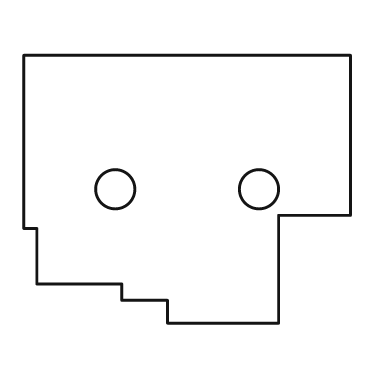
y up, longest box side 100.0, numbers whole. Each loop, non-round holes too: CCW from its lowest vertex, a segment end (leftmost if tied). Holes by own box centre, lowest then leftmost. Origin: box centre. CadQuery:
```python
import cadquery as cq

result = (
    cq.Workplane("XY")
    .moveTo(-6.0, -41.0)
    .lineTo(28.0, -41.0)
    .lineTo(28.0, -8.0)
    .lineTo(50.0, -8.0)
    .lineTo(50.0, 41.0)
    .lineTo(-50.0, 41.0)
    .lineTo(-50.0, -12.0)
    .lineTo(-46.0, -12.0)
    .lineTo(-46.0, -29.0)
    .lineTo(-20.0, -29.0)
    .lineTo(-20.0, -34.0)
    .lineTo(-6.0, -34.0)
    .close()
    .moveTo(-22.0, 0.0)
    .circle(6.0)
    .moveTo(22.0, 0.0)
    .circle(6.0)
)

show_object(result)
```